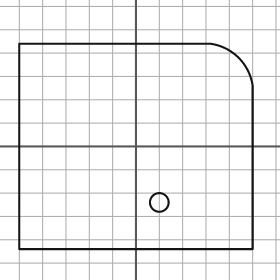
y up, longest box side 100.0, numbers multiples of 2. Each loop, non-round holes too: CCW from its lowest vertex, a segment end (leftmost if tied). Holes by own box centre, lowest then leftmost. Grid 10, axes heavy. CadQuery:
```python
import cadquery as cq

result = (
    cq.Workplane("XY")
    .moveTo(-50.0, -44.0)
    .lineTo(50.0, -44.0)
    .lineTo(50.0, 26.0)
    .threePointArc((44.0, 38.0), (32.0, 44.0))
    .lineTo(-50.0, 44.0)
    .close()
    .moveTo(10.0, -24.0)
    .circle(4.0)
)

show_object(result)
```